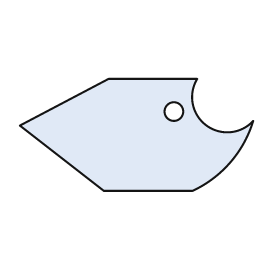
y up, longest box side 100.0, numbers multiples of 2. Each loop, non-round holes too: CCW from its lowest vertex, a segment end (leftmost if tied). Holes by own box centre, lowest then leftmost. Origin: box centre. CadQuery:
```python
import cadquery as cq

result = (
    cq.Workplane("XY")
    .moveTo(-14.0, -24.0)
    .lineTo(24.0, -24.0)
    .threePointArc((40.0, -12.0), (50.0, 6.0))
    .threePointArc((30.0, 4.0), (26.0, 24.0))
    .lineTo(-12.0, 24.0)
    .lineTo(-50.0, 4.0)
    .close()
    .moveTo(16.0, 10.0)
    .circle(4.0)
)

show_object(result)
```